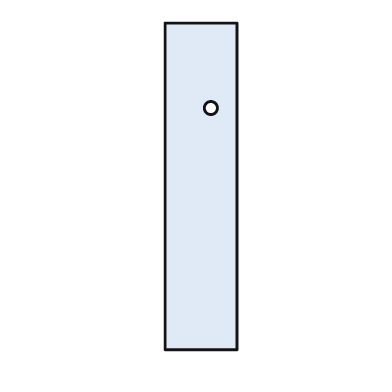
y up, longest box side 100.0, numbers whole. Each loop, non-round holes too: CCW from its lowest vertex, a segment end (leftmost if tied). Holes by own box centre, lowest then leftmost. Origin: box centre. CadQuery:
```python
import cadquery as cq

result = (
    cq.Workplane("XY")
    .moveTo(-11.0, -50.0)
    .lineTo(11.0, -50.0)
    .lineTo(11.0, 50.0)
    .lineTo(-11.0, 50.0)
    .close()
    .moveTo(3.0, 24.0)
    .circle(2.0)
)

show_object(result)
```